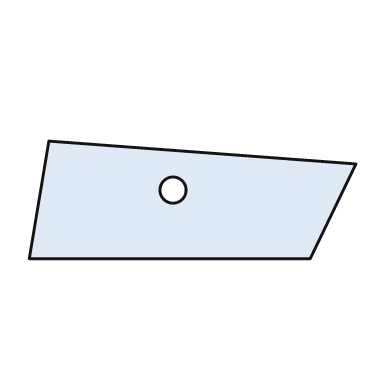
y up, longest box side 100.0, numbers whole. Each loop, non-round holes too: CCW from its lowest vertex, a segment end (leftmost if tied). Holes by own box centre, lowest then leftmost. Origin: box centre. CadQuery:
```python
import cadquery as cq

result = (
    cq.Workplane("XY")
    .moveTo(-50.0, -18.0)
    .lineTo(36.0, -18.0)
    .lineTo(50.0, 11.0)
    .lineTo(-44.0, 18.0)
    .close()
    .moveTo(-6.0, 3.0)
    .circle(4.0)
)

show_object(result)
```